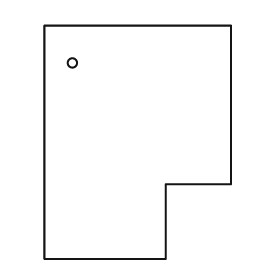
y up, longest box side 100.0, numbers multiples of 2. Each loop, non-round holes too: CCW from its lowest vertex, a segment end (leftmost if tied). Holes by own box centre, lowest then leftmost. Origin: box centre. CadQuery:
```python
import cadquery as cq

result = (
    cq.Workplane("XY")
    .moveTo(-40.0, -50.0)
    .lineTo(12.0, -50.0)
    .lineTo(12.0, -18.0)
    .lineTo(40.0, -18.0)
    .lineTo(40.0, 50.0)
    .lineTo(-40.0, 50.0)
    .close()
    .moveTo(-28.0, 34.0)
    .circle(2.0)
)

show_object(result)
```